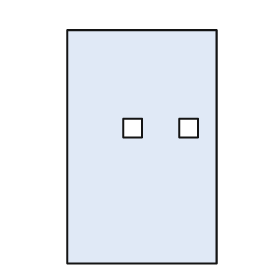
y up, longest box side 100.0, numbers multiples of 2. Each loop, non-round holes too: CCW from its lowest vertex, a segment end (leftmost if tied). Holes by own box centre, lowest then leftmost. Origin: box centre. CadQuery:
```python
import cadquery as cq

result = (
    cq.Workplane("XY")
    .moveTo(-32.0, -50.0)
    .lineTo(32.0, -50.0)
    .lineTo(32.0, 50.0)
    .lineTo(-32.0, 50.0)
    .close()
    .moveTo(-8.0, 4.0)
    .lineTo(0.0, 4.0)
    .lineTo(0.0, 12.0)
    .lineTo(-8.0, 12.0)
    .close()
    .moveTo(16.0, 4.0)
    .lineTo(24.0, 4.0)
    .lineTo(24.0, 12.0)
    .lineTo(16.0, 12.0)
    .close()
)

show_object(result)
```